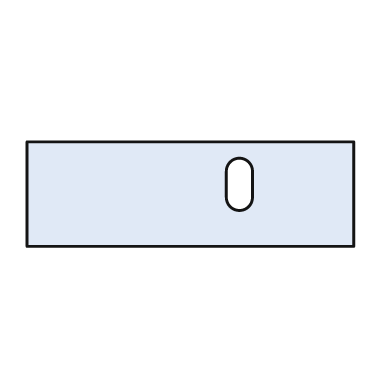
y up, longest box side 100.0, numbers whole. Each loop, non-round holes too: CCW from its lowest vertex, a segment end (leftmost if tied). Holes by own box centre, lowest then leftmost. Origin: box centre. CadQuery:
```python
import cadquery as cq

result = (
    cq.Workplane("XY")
    .moveTo(-50.0, -16.0)
    .lineTo(50.0, -16.0)
    .lineTo(50.0, 16.0)
    .lineTo(-50.0, 16.0)
    .close()
    .moveTo(11.0, -1.0)
    .threePointArc((15.0, -5.0), (19.0, -1.0))
    .lineTo(19.0, 7.0)
    .threePointArc((15.0, 11.0), (11.0, 7.0))
    .close()
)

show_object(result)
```